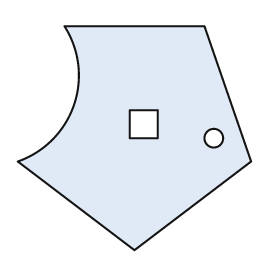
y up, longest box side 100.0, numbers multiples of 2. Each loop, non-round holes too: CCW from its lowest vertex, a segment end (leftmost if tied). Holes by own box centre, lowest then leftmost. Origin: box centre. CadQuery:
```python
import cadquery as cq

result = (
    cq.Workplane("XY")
    .moveTo(0.0, -48.0)
    .lineTo(50.0, -10.0)
    .lineTo(30.0, 48.0)
    .lineTo(-30.0, 48.0)
    .threePointArc((-26.0, 14.0), (-50.0, -10.0))
    .close()
    .moveTo(34.0, 0.0)
    .circle(4.0)
    .moveTo(-2.0, 0.0)
    .lineTo(10.0, 0.0)
    .lineTo(10.0, 12.0)
    .lineTo(-2.0, 12.0)
    .close()
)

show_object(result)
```